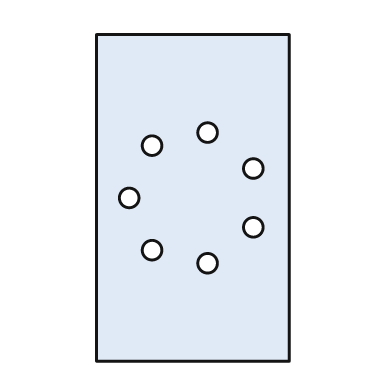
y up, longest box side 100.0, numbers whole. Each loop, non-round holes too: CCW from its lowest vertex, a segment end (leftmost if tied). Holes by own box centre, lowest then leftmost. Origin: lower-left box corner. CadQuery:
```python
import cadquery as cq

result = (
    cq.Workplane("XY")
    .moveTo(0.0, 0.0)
    .lineTo(59.0, 0.0)
    .lineTo(59.0, 100.0)
    .lineTo(0.0, 100.0)
    .close()
    .moveTo(34.0, 30.0)
    .circle(3.0)
    .moveTo(17.0, 34.0)
    .circle(3.0)
    .moveTo(48.0, 41.0)
    .circle(3.0)
    .moveTo(10.0, 50.0)
    .circle(3.0)
    .moveTo(48.0, 59.0)
    .circle(3.0)
    .moveTo(17.0, 66.0)
    .circle(3.0)
    .moveTo(34.0, 70.0)
    .circle(3.0)
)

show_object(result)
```